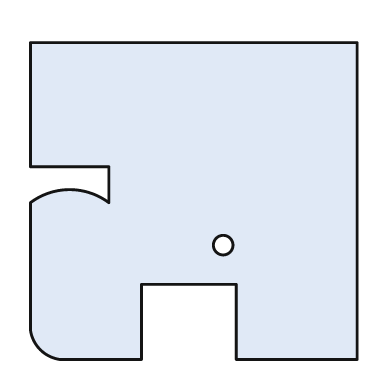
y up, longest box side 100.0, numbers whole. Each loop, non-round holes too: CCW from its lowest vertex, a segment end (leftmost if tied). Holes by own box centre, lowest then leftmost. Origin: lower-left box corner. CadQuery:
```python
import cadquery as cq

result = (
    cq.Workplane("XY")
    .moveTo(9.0, 0.0)
    .lineTo(34.0, 0.0)
    .lineTo(34.0, 23.0)
    .lineTo(63.0, 23.0)
    .lineTo(63.0, 0.0)
    .lineTo(100.0, 0.0)
    .lineTo(100.0, 97.0)
    .lineTo(0.0, 97.0)
    .lineTo(0.0, 59.0)
    .lineTo(24.0, 59.0)
    .lineTo(24.0, 48.0)
    .threePointArc((12.0, 52.0), (0.0, 48.0))
    .lineTo(0.0, 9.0)
    .threePointArc((3.0, 3.0), (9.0, 0.0))
    .close()
    .moveTo(59.0, 35.0)
    .circle(3.0)
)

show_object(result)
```